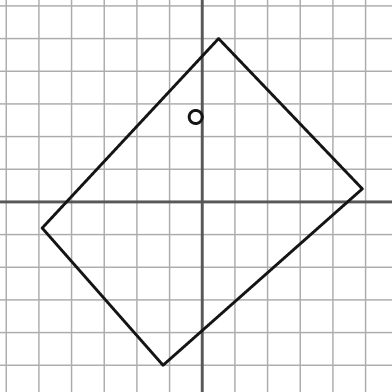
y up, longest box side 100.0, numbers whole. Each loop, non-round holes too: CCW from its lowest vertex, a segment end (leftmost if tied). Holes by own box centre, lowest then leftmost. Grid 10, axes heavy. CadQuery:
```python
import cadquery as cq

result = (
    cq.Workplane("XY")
    .moveTo(-12.0, -50.0)
    .lineTo(49.0, 4.0)
    .lineTo(5.0, 50.0)
    .lineTo(-49.0, -8.0)
    .close()
    .moveTo(-2.0, 26.0)
    .circle(2.0)
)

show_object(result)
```